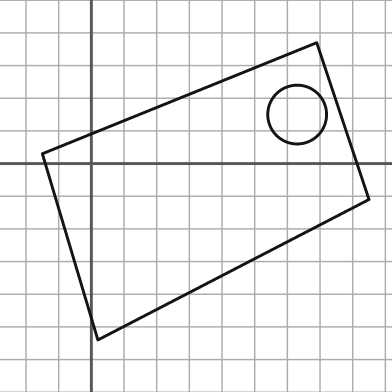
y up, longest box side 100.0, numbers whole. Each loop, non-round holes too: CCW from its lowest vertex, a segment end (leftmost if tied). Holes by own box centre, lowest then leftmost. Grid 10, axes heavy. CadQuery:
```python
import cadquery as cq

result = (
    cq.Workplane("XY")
    .moveTo(2.0, -54.0)
    .lineTo(85.0, -11.0)
    .lineTo(69.0, 37.0)
    .lineTo(-15.0, 3.0)
    .close()
    .moveTo(63.0, 15.0)
    .circle(9.0)
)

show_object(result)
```